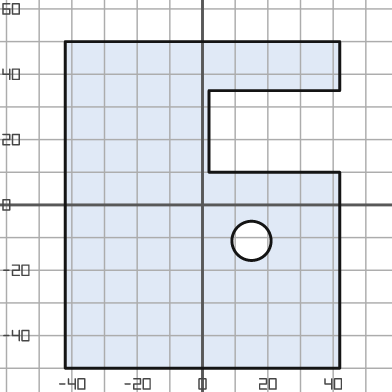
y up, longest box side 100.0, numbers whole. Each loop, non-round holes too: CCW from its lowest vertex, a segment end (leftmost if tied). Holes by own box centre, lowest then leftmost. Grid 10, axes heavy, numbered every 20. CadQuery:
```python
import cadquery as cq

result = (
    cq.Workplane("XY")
    .moveTo(-42.0, -50.0)
    .lineTo(42.0, -50.0)
    .lineTo(42.0, 10.0)
    .lineTo(2.0, 10.0)
    .lineTo(2.0, 35.0)
    .lineTo(42.0, 35.0)
    .lineTo(42.0, 50.0)
    .lineTo(-42.0, 50.0)
    .close()
    .moveTo(15.0, -11.0)
    .circle(6.0)
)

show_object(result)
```